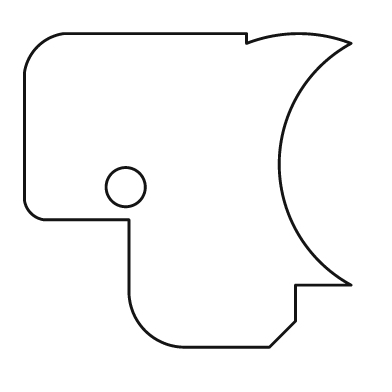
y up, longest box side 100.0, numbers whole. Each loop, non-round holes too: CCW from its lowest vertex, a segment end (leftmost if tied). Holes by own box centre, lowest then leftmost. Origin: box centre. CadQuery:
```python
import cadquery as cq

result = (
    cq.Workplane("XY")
    .moveTo(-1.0, -48.0)
    .lineTo(25.0, -48.0)
    .lineTo(33.0, -40.0)
    .lineTo(33.0, -29.0)
    .lineTo(50.0, -29.0)
    .threePointArc((28.0, 8.0), (50.0, 45.0))
    .threePointArc((34.0, 48.0), (18.0, 45.0))
    .lineTo(18.0, 48.0)
    .lineTo(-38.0, 48.0)
    .threePointArc((-46.0, 44.0), (-50.0, 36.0))
    .lineTo(-50.0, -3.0)
    .threePointArc((-48.0, -7.0), (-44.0, -9.0))
    .lineTo(-18.0, -9.0)
    .lineTo(-18.0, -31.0)
    .threePointArc((-13.0, -43.0), (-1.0, -48.0))
    .close()
    .moveTo(-19.0, 1.0)
    .circle(6.0)
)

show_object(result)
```